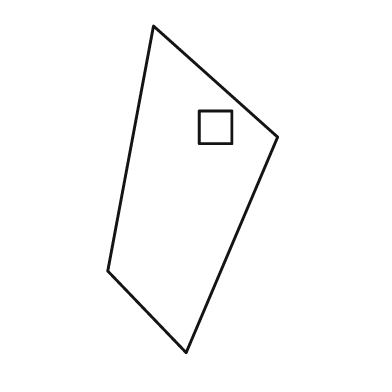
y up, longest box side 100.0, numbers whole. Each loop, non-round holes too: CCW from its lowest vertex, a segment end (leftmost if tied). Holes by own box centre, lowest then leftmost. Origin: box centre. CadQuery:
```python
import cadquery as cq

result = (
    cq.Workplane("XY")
    .moveTo(-2.0, -50.0)
    .lineTo(26.0, 16.0)
    .lineTo(-12.0, 50.0)
    .lineTo(-26.0, -25.0)
    .close()
    .moveTo(2.0, 14.0)
    .lineTo(12.0, 14.0)
    .lineTo(12.0, 24.0)
    .lineTo(2.0, 24.0)
    .close()
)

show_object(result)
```